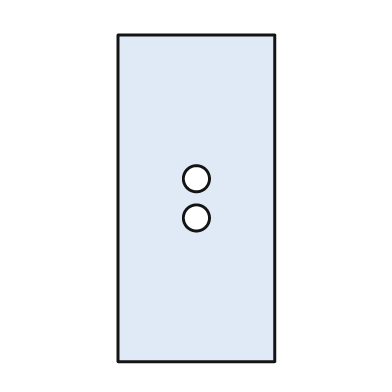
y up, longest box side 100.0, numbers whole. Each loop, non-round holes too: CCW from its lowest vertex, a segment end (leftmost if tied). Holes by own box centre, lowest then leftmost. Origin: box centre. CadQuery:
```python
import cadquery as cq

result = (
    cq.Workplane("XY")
    .moveTo(-24.0, -50.0)
    .lineTo(24.0, -50.0)
    .lineTo(24.0, 50.0)
    .lineTo(-24.0, 50.0)
    .close()
    .moveTo(0.0, -6.0)
    .circle(4.0)
    .moveTo(0.0, 6.0)
    .circle(4.0)
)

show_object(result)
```